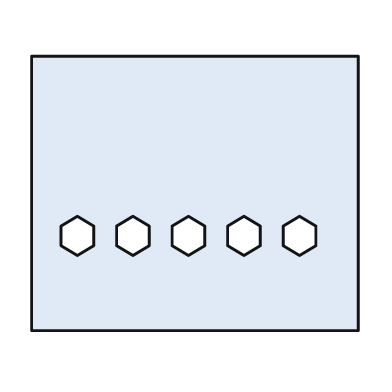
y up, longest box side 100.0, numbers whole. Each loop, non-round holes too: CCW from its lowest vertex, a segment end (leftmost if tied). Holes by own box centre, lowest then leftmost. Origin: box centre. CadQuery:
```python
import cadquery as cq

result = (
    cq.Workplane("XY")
    .moveTo(-50.0, -42.0)
    .lineTo(50.0, -42.0)
    .lineTo(50.0, 42.0)
    .lineTo(-50.0, 42.0)
    .close()
    .moveTo(-36.0, -19.0)
    .lineTo(-31.0, -16.0)
    .lineTo(-31.0, -10.0)
    .lineTo(-36.0, -7.0)
    .lineTo(-41.0, -10.0)
    .lineTo(-41.0, -16.0)
    .close()
    .moveTo(-19.0, -19.0)
    .lineTo(-14.0, -16.0)
    .lineTo(-14.0, -10.0)
    .lineTo(-19.0, -7.0)
    .lineTo(-24.0, -10.0)
    .lineTo(-24.0, -16.0)
    .close()
    .moveTo(-2.0, -19.0)
    .lineTo(3.0, -16.0)
    .lineTo(3.0, -10.0)
    .lineTo(-2.0, -7.0)
    .lineTo(-7.0, -10.0)
    .lineTo(-7.0, -16.0)
    .close()
    .moveTo(15.0, -19.0)
    .lineTo(20.0, -16.0)
    .lineTo(20.0, -10.0)
    .lineTo(15.0, -7.0)
    .lineTo(10.0, -10.0)
    .lineTo(10.0, -16.0)
    .close()
    .moveTo(32.0, -19.0)
    .lineTo(37.0, -16.0)
    .lineTo(37.0, -10.0)
    .lineTo(32.0, -7.0)
    .lineTo(27.0, -10.0)
    .lineTo(27.0, -16.0)
    .close()
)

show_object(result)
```